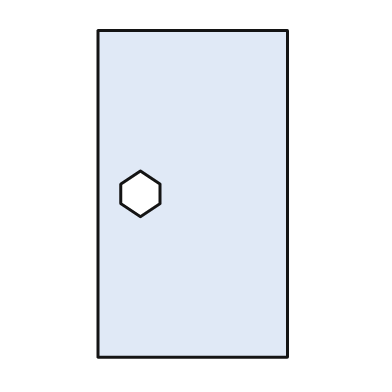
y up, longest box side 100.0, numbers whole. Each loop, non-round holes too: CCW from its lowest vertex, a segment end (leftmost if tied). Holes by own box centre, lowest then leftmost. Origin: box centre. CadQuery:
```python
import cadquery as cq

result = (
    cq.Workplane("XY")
    .moveTo(-29.0, -50.0)
    .lineTo(29.0, -50.0)
    .lineTo(29.0, 50.0)
    .lineTo(-29.0, 50.0)
    .close()
    .moveTo(-16.0, -7.0)
    .lineTo(-10.0, -3.0)
    .lineTo(-10.0, 3.0)
    .lineTo(-16.0, 7.0)
    .lineTo(-22.0, 3.0)
    .lineTo(-22.0, -3.0)
    .close()
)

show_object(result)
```